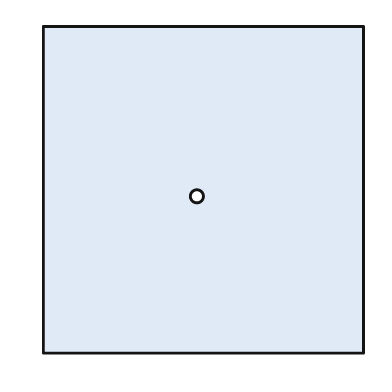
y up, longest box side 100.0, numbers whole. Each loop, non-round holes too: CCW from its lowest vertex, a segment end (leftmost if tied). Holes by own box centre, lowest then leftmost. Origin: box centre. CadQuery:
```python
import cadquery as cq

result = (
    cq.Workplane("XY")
    .moveTo(-49.0, -50.0)
    .lineTo(49.0, -50.0)
    .lineTo(49.0, 50.0)
    .lineTo(-49.0, 50.0)
    .close()
    .moveTo(-2.0, -2.0)
    .circle(2.0)
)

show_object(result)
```